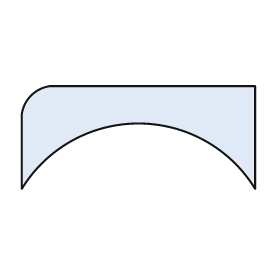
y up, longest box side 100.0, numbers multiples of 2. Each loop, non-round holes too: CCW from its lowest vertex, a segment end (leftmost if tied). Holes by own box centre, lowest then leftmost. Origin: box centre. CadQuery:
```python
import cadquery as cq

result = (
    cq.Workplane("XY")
    .moveTo(-50.0, -22.0)
    .threePointArc((0.0, 6.0), (50.0, -22.0))
    .lineTo(50.0, 22.0)
    .lineTo(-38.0, 22.0)
    .threePointArc((-46.0, 18.0), (-50.0, 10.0))
    .close()
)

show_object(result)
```